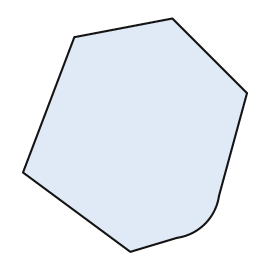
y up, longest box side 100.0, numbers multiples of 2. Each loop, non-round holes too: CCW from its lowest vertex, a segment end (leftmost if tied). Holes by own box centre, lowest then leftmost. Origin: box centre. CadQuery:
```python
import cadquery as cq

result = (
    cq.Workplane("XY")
    .moveTo(-2.0, -50.0)
    .lineTo(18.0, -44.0)
    .threePointArc((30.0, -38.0), (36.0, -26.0))
    .lineTo(48.0, 18.0)
    .lineTo(16.0, 50.0)
    .lineTo(-26.0, 42.0)
    .lineTo(-48.0, -16.0)
    .close()
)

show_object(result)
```